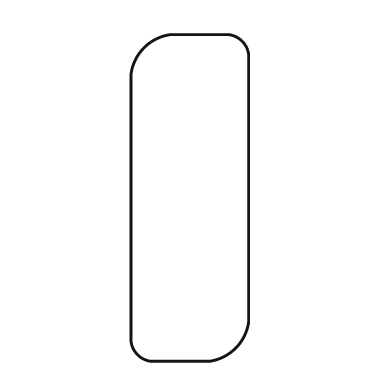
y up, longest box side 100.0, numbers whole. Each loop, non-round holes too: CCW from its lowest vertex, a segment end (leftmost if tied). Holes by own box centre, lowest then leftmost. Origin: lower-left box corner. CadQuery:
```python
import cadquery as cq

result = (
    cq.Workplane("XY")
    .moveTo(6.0, 0.0)
    .lineTo(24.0, 0.0)
    .threePointArc((32.0, 4.0), (36.0, 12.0))
    .lineTo(36.0, 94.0)
    .threePointArc((34.0, 98.0), (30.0, 100.0))
    .lineTo(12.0, 100.0)
    .threePointArc((4.0, 96.0), (0.0, 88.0))
    .lineTo(0.0, 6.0)
    .threePointArc((2.0, 2.0), (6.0, 0.0))
    .close()
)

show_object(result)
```